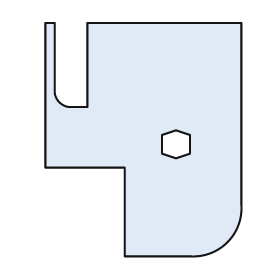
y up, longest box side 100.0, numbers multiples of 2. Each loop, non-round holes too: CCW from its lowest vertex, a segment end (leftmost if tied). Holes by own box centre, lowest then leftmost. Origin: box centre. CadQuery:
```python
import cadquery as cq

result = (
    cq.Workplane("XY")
    .moveTo(-8.0, -50.0)
    .lineTo(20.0, -50.0)
    .threePointArc((36.0, -44.0), (42.0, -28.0))
    .lineTo(42.0, 50.0)
    .lineTo(-24.0, 50.0)
    .lineTo(-24.0, 14.0)
    .lineTo(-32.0, 14.0)
    .threePointArc((-36.0, 16.0), (-38.0, 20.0))
    .lineTo(-38.0, 50.0)
    .lineTo(-42.0, 50.0)
    .lineTo(-42.0, -12.0)
    .lineTo(-8.0, -12.0)
    .close()
    .moveTo(14.0, -8.0)
    .lineTo(20.0, -6.0)
    .lineTo(20.0, 2.0)
    .lineTo(14.0, 4.0)
    .lineTo(8.0, 2.0)
    .lineTo(8.0, -6.0)
    .close()
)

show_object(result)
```